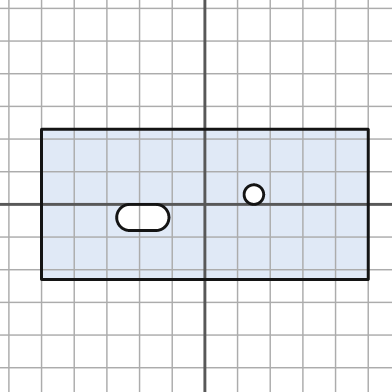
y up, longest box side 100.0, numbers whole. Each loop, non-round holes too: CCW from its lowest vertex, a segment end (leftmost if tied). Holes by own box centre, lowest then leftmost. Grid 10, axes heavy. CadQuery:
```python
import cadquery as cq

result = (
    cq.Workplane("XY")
    .moveTo(-50.0, -23.0)
    .lineTo(50.0, -23.0)
    .lineTo(50.0, 23.0)
    .lineTo(-50.0, 23.0)
    .close()
    .moveTo(-23.0, -8.0)
    .lineTo(-15.0, -8.0)
    .threePointArc((-11.0, -4.0), (-15.0, 0.0))
    .lineTo(-23.0, 0.0)
    .threePointArc((-27.0, -4.0), (-23.0, -8.0))
    .close()
    .moveTo(15.0, 3.0)
    .circle(3.0)
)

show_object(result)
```